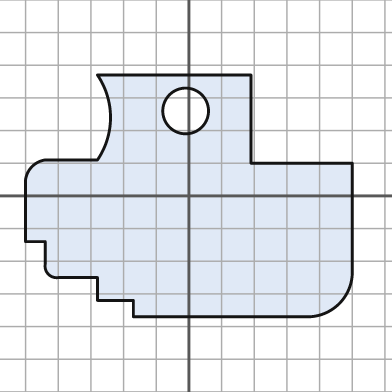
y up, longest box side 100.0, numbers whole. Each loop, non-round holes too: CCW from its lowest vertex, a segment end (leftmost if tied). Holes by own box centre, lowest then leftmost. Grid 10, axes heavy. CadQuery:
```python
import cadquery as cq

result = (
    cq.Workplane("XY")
    .moveTo(-17.0, -37.0)
    .lineTo(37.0, -37.0)
    .threePointArc((46.0, -33.0), (50.0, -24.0))
    .lineTo(50.0, 10.0)
    .lineTo(19.0, 10.0)
    .lineTo(19.0, 37.0)
    .lineTo(-28.0, 37.0)
    .threePointArc((-24.0, 24.0), (-28.0, 11.0))
    .lineTo(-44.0, 11.0)
    .threePointArc((-48.0, 9.0), (-50.0, 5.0))
    .lineTo(-50.0, -14.0)
    .lineTo(-44.0, -14.0)
    .lineTo(-44.0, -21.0)
    .threePointArc((-43.0, -24.0), (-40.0, -25.0))
    .lineTo(-28.0, -25.0)
    .lineTo(-28.0, -32.0)
    .lineTo(-17.0, -32.0)
    .close()
    .moveTo(-1.0, 26.0)
    .circle(7.0)
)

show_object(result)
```